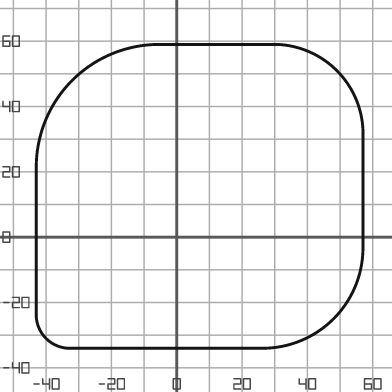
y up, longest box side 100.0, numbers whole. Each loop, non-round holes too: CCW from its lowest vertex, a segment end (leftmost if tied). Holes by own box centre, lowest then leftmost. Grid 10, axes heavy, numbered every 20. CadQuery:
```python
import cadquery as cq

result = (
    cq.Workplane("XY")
    .moveTo(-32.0, -34.0)
    .lineTo(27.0, -34.0)
    .threePointArc((48.0, -25.0), (57.0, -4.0))
    .lineTo(57.0, 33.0)
    .threePointArc((49.0, 51.0), (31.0, 59.0))
    .lineTo(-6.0, 59.0)
    .threePointArc((-32.0, 48.0), (-43.0, 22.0))
    .lineTo(-43.0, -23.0)
    .threePointArc((-40.0, -31.0), (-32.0, -34.0))
    .close()
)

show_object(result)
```